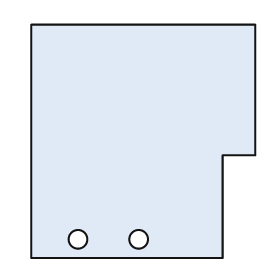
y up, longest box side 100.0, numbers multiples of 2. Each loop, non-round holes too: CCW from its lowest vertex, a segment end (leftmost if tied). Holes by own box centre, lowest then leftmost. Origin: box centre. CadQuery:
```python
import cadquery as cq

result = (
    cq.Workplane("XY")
    .moveTo(-48.0, -50.0)
    .lineTo(34.0, -50.0)
    .lineTo(34.0, -6.0)
    .lineTo(48.0, -6.0)
    .lineTo(48.0, 50.0)
    .lineTo(-48.0, 50.0)
    .close()
    .moveTo(-28.0, -42.0)
    .circle(4.0)
    .moveTo(-2.0, -42.0)
    .circle(4.0)
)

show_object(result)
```